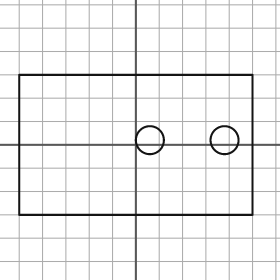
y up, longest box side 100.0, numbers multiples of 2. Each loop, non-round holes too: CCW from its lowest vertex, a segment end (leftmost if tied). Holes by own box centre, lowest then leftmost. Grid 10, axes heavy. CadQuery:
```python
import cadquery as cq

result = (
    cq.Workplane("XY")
    .moveTo(-50.0, -30.0)
    .lineTo(50.0, -30.0)
    .lineTo(50.0, 30.0)
    .lineTo(-50.0, 30.0)
    .close()
    .moveTo(6.0, 2.0)
    .circle(6.0)
    .moveTo(38.0, 2.0)
    .circle(6.0)
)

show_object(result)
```